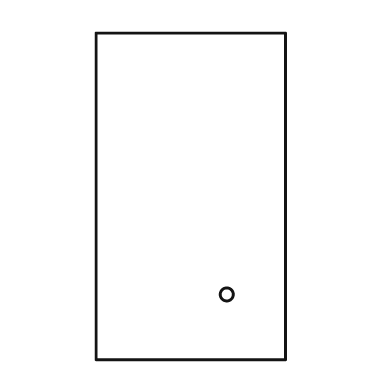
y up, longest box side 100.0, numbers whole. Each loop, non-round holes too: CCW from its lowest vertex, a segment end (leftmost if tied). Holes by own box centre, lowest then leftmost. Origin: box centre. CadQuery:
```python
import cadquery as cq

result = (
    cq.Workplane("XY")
    .moveTo(-29.0, -50.0)
    .lineTo(29.0, -50.0)
    .lineTo(29.0, 50.0)
    .lineTo(-29.0, 50.0)
    .close()
    .moveTo(11.0, -30.0)
    .circle(2.0)
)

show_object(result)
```